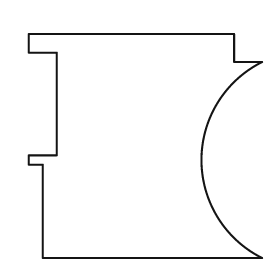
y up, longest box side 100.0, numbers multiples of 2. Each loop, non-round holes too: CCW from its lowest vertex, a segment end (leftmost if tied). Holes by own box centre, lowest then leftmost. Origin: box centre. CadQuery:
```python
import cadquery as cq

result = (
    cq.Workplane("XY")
    .moveTo(-44.0, -48.0)
    .lineTo(50.0, -48.0)
    .threePointArc((24.0, -6.0), (50.0, 36.0))
    .lineTo(38.0, 36.0)
    .lineTo(38.0, 48.0)
    .lineTo(-50.0, 48.0)
    .lineTo(-50.0, 40.0)
    .lineTo(-38.0, 40.0)
    .lineTo(-38.0, -4.0)
    .lineTo(-50.0, -4.0)
    .lineTo(-50.0, -8.0)
    .lineTo(-44.0, -8.0)
    .close()
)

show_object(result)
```